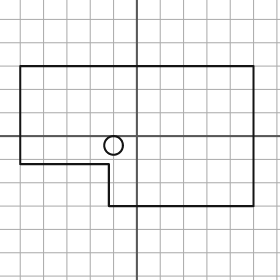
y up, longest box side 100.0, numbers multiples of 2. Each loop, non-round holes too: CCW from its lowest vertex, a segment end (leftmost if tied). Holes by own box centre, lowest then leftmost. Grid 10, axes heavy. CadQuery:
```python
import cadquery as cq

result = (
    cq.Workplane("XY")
    .moveTo(-12.0, -30.0)
    .lineTo(50.0, -30.0)
    .lineTo(50.0, 30.0)
    .lineTo(-50.0, 30.0)
    .lineTo(-50.0, -12.0)
    .lineTo(-12.0, -12.0)
    .close()
    .moveTo(-10.0, -4.0)
    .circle(4.0)
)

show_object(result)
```